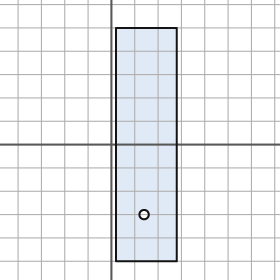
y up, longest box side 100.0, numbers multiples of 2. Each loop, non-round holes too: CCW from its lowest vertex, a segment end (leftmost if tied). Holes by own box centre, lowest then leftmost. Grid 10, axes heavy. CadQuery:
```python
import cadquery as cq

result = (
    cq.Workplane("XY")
    .moveTo(2.0, -50.0)
    .lineTo(28.0, -50.0)
    .lineTo(28.0, 50.0)
    .lineTo(2.0, 50.0)
    .close()
    .moveTo(14.0, -30.0)
    .circle(2.0)
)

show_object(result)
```